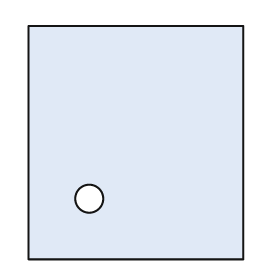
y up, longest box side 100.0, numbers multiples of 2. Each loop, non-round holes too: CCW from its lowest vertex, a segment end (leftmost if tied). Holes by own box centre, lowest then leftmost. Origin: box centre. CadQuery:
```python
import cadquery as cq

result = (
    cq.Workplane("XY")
    .moveTo(-46.0, -50.0)
    .lineTo(46.0, -50.0)
    .lineTo(46.0, 50.0)
    .lineTo(-46.0, 50.0)
    .close()
    .moveTo(-20.0, -24.0)
    .circle(6.0)
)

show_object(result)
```